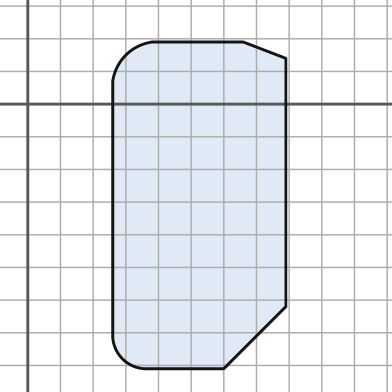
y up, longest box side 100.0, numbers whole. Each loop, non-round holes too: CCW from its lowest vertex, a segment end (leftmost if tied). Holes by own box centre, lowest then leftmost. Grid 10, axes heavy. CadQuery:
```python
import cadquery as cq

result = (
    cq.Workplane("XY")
    .moveTo(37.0, -81.0)
    .lineTo(60.0, -81.0)
    .lineTo(79.0, -62.0)
    .lineTo(79.0, 14.0)
    .lineTo(66.0, 19.0)
    .lineTo(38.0, 19.0)
    .threePointArc((30.0, 15.0), (26.0, 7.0))
    .lineTo(26.0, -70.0)
    .threePointArc((29.0, -78.0), (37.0, -81.0))
    .close()
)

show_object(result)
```